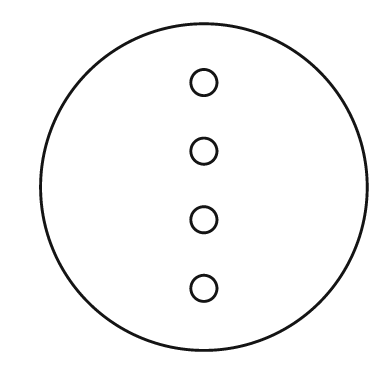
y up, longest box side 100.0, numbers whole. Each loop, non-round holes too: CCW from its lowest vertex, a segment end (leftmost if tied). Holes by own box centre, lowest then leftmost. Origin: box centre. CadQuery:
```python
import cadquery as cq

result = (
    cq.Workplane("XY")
    .moveTo(0.0, 0.0)
    .circle(50.0)
    .moveTo(0.0, -31.0)
    .circle(4.0)
    .moveTo(0.0, -10.0)
    .circle(4.0)
    .moveTo(0.0, 11.0)
    .circle(4.0)
    .moveTo(0.0, 32.0)
    .circle(4.0)
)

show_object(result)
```